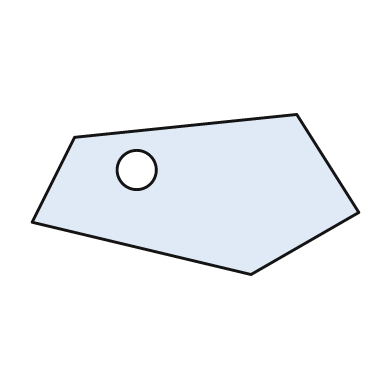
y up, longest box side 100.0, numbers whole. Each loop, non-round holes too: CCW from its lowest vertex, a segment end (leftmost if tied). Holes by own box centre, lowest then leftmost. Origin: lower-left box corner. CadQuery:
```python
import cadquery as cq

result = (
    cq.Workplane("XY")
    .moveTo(67.0, 0.0)
    .lineTo(100.0, 19.0)
    .lineTo(81.0, 49.0)
    .lineTo(13.0, 42.0)
    .lineTo(0.0, 16.0)
    .close()
    .moveTo(32.0, 32.0)
    .circle(6.0)
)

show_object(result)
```